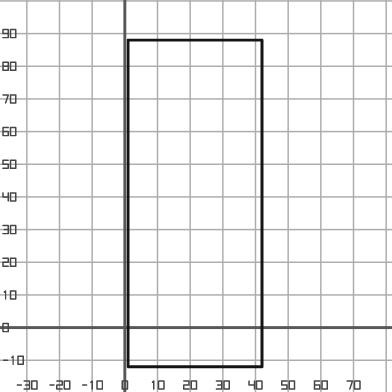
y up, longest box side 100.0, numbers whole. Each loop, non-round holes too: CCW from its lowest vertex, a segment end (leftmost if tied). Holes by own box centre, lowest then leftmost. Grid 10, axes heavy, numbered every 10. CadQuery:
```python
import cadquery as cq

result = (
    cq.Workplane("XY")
    .moveTo(1.0, -12.0)
    .lineTo(42.0, -12.0)
    .lineTo(42.0, 88.0)
    .lineTo(1.0, 88.0)
    .close()
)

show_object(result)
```